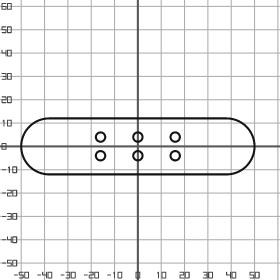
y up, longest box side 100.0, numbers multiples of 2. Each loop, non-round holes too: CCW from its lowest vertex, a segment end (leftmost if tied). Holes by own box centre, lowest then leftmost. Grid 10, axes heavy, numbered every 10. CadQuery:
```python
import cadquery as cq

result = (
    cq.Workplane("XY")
    .moveTo(-38.0, -12.0)
    .lineTo(38.0, -12.0)
    .threePointArc((50.0, 0.0), (38.0, 12.0))
    .lineTo(-38.0, 12.0)
    .threePointArc((-50.0, 0.0), (-38.0, -12.0))
    .close()
    .moveTo(-16.0, -4.0)
    .circle(2.0)
    .moveTo(0.0, -4.0)
    .circle(2.0)
    .moveTo(16.0, -4.0)
    .circle(2.0)
    .moveTo(-16.0, 4.0)
    .circle(2.0)
    .moveTo(0.0, 4.0)
    .circle(2.0)
    .moveTo(16.0, 4.0)
    .circle(2.0)
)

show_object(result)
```